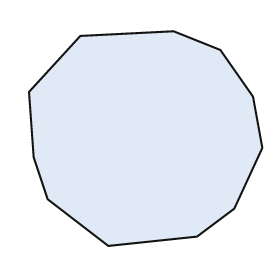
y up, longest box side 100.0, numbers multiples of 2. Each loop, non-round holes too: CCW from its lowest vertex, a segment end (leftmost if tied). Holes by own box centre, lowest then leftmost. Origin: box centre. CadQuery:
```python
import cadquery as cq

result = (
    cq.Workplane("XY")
    .moveTo(-16.0, -46.0)
    .lineTo(22.0, -42.0)
    .lineTo(38.0, -30.0)
    .lineTo(50.0, -4.0)
    .lineTo(46.0, 18.0)
    .lineTo(32.0, 38.0)
    .lineTo(12.0, 46.0)
    .lineTo(-28.0, 44.0)
    .lineTo(-50.0, 20.0)
    .lineTo(-48.0, -8.0)
    .lineTo(-42.0, -26.0)
    .close()
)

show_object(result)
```